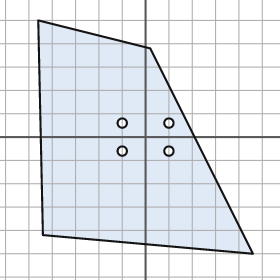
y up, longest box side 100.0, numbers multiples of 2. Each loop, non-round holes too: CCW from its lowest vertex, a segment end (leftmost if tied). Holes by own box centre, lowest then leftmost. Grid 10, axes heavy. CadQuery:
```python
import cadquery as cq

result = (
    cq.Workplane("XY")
    .moveTo(46.0, -50.0)
    .lineTo(2.0, 38.0)
    .lineTo(-46.0, 50.0)
    .lineTo(-44.0, -42.0)
    .close()
    .moveTo(-10.0, -6.0)
    .circle(2.0)
    .moveTo(10.0, -6.0)
    .circle(2.0)
    .moveTo(-10.0, 6.0)
    .circle(2.0)
    .moveTo(10.0, 6.0)
    .circle(2.0)
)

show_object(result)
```